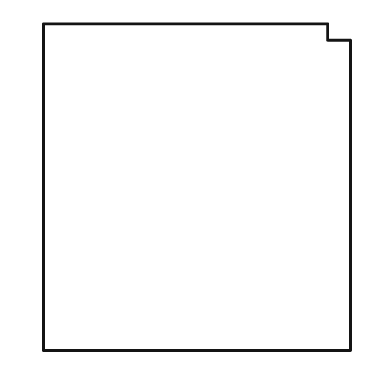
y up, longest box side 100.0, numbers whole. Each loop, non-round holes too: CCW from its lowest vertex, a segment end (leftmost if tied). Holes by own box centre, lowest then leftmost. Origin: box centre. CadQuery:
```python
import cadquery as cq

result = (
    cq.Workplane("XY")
    .moveTo(-47.0, -50.0)
    .lineTo(47.0, -50.0)
    .lineTo(47.0, 45.0)
    .lineTo(40.0, 45.0)
    .lineTo(40.0, 50.0)
    .lineTo(-47.0, 50.0)
    .close()
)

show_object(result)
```